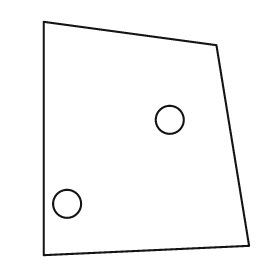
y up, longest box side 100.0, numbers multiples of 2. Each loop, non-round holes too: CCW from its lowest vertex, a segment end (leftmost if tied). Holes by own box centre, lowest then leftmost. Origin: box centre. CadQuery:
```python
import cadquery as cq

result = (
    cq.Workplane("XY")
    .moveTo(-44.0, -50.0)
    .lineTo(44.0, -46.0)
    .lineTo(30.0, 40.0)
    .lineTo(-44.0, 50.0)
    .close()
    .moveTo(-34.0, -28.0)
    .circle(6.0)
    .moveTo(10.0, 8.0)
    .circle(6.0)
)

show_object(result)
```